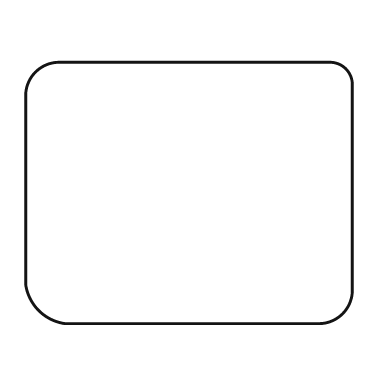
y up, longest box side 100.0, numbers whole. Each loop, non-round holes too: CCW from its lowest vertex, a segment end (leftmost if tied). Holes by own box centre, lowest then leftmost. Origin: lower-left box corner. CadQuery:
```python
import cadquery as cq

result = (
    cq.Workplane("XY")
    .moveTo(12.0, 0.0)
    .lineTo(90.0, 0.0)
    .threePointArc((97.0, 3.0), (100.0, 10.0))
    .lineTo(100.0, 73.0)
    .threePointArc((98.0, 78.0), (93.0, 80.0))
    .lineTo(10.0, 80.0)
    .threePointArc((3.0, 77.0), (0.0, 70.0))
    .lineTo(0.0, 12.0)
    .threePointArc((4.0, 4.0), (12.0, 0.0))
    .close()
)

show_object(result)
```